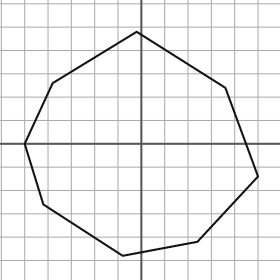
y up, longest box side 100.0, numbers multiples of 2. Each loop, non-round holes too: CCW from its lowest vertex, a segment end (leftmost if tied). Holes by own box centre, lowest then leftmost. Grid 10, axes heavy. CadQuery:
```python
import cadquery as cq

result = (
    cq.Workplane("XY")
    .moveTo(-8.0, -48.0)
    .lineTo(24.0, -42.0)
    .lineTo(50.0, -14.0)
    .lineTo(36.0, 24.0)
    .lineTo(-2.0, 48.0)
    .lineTo(-38.0, 26.0)
    .lineTo(-50.0, 0.0)
    .lineTo(-42.0, -26.0)
    .close()
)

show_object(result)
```